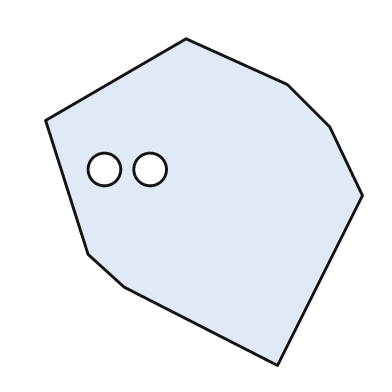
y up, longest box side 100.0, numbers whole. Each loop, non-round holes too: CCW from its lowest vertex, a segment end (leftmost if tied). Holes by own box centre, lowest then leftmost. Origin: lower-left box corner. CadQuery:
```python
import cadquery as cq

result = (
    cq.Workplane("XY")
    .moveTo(71.0, 0.0)
    .lineTo(97.0, 52.0)
    .lineTo(87.0, 73.0)
    .lineTo(74.0, 86.0)
    .lineTo(43.0, 100.0)
    .lineTo(0.0, 75.0)
    .lineTo(13.0, 34.0)
    .lineTo(24.0, 24.0)
    .close()
    .moveTo(18.0, 60.0)
    .circle(5.0)
    .moveTo(32.0, 60.0)
    .circle(5.0)
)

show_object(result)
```